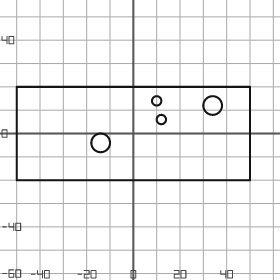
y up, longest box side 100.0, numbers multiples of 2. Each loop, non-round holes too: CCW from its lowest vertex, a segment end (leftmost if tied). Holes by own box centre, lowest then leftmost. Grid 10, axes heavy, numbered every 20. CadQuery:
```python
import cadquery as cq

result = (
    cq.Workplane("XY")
    .moveTo(-50.0, -20.0)
    .lineTo(50.0, -20.0)
    .lineTo(50.0, 20.0)
    .lineTo(-50.0, 20.0)
    .close()
    .moveTo(-14.0, -4.0)
    .circle(4.0)
    .moveTo(12.0, 6.0)
    .circle(2.0)
    .moveTo(34.0, 12.0)
    .circle(4.0)
    .moveTo(10.0, 14.0)
    .circle(2.0)
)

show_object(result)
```